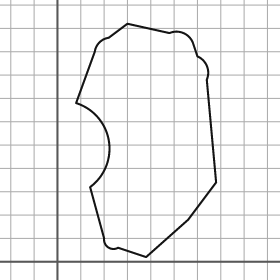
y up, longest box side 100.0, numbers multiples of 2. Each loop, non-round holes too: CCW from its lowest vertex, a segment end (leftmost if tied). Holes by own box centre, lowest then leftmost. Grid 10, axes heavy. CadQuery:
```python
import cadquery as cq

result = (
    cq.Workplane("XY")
    .moveTo(38.0, 2.0)
    .lineTo(56.0, 18.0)
    .lineTo(68.0, 34.0)
    .lineTo(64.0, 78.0)
    .threePointArc((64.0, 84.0), (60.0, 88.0))
    .lineTo(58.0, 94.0)
    .threePointArc((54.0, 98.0), (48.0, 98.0))
    .lineTo(30.0, 102.0)
    .lineTo(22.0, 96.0)
    .threePointArc((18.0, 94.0), (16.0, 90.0))
    .lineTo(8.0, 68.0)
    .threePointArc((22.0, 52.0), (14.0, 32.0))
    .lineTo(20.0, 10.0)
    .threePointArc((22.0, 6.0), (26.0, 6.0))
    .close()
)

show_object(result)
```